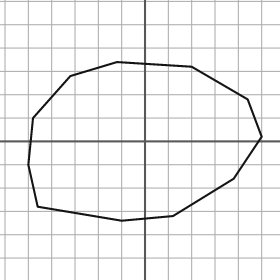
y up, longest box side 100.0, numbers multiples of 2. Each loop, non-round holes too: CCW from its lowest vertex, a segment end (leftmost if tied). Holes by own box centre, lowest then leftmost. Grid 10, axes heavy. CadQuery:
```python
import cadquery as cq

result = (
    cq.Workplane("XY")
    .moveTo(-10.0, -34.0)
    .lineTo(12.0, -32.0)
    .lineTo(38.0, -16.0)
    .lineTo(50.0, 2.0)
    .lineTo(44.0, 18.0)
    .lineTo(20.0, 32.0)
    .lineTo(-12.0, 34.0)
    .lineTo(-32.0, 28.0)
    .lineTo(-48.0, 10.0)
    .lineTo(-50.0, -10.0)
    .lineTo(-46.0, -28.0)
    .close()
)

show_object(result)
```